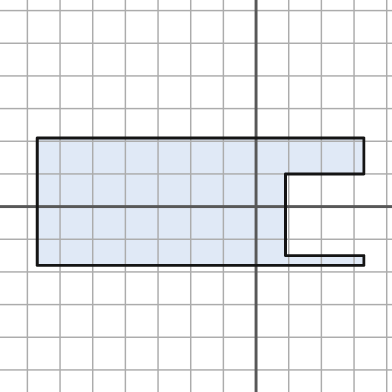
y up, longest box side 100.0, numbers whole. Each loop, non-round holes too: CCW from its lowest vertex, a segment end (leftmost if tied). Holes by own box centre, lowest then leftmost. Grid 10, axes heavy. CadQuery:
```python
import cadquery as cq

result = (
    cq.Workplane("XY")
    .moveTo(-67.0, -18.0)
    .lineTo(33.0, -18.0)
    .lineTo(33.0, -15.0)
    .lineTo(9.0, -15.0)
    .lineTo(9.0, 10.0)
    .lineTo(33.0, 10.0)
    .lineTo(33.0, 21.0)
    .lineTo(-67.0, 21.0)
    .close()
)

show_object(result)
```